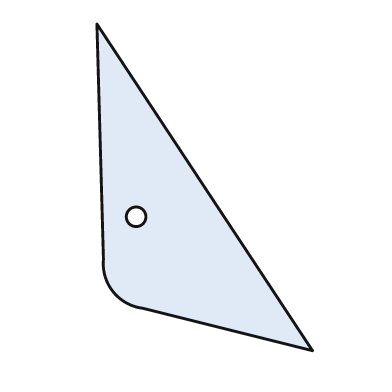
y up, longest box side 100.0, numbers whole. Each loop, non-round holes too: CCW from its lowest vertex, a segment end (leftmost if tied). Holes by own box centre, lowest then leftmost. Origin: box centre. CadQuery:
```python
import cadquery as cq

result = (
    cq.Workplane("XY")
    .moveTo(33.0, -50.0)
    .lineTo(-33.0, 50.0)
    .lineTo(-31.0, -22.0)
    .threePointArc((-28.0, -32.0), (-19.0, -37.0))
    .close()
    .moveTo(-21.0, -9.0)
    .circle(3.0)
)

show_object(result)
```